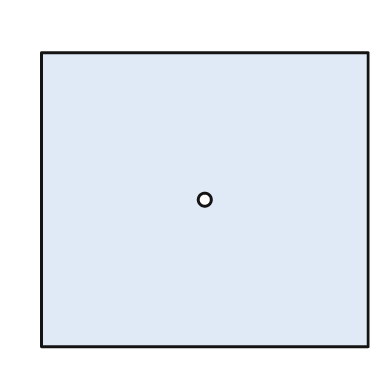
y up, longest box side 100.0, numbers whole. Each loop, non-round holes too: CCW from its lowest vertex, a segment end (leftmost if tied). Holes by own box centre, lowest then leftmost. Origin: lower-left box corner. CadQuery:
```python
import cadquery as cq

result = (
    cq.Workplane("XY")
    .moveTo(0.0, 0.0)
    .lineTo(100.0, 0.0)
    .lineTo(100.0, 90.0)
    .lineTo(0.0, 90.0)
    .close()
    .moveTo(50.0, 45.0)
    .circle(2.0)
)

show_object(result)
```